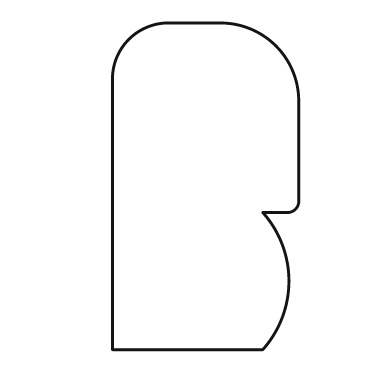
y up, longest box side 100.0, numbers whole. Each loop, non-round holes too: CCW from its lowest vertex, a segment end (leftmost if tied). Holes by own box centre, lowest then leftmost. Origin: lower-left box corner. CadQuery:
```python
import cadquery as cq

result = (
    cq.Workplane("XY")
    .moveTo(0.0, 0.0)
    .lineTo(46.0, 0.0)
    .threePointArc((54.0, 21.0), (46.0, 42.0))
    .lineTo(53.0, 42.0)
    .threePointArc((56.0, 43.0), (57.0, 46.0))
    .lineTo(57.0, 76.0)
    .threePointArc((50.0, 93.0), (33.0, 100.0))
    .lineTo(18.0, 100.0)
    .threePointArc((5.0, 95.0), (0.0, 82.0))
    .close()
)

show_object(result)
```